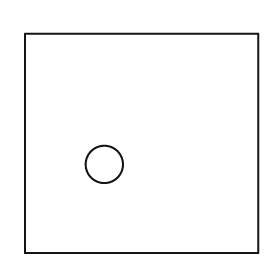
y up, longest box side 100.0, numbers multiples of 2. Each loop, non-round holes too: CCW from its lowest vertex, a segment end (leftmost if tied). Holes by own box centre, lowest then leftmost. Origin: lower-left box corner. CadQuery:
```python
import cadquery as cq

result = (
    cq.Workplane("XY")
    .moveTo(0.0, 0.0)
    .lineTo(100.0, 0.0)
    .lineTo(100.0, 94.0)
    .lineTo(0.0, 94.0)
    .close()
    .moveTo(34.0, 38.0)
    .circle(8.0)
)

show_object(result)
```